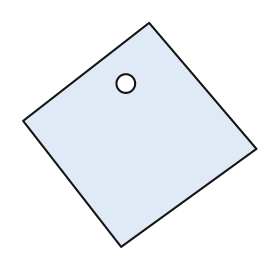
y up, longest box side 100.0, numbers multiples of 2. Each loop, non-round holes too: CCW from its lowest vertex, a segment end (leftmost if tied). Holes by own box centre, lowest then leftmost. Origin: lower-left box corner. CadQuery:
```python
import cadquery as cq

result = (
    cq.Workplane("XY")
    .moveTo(42.0, 0.0)
    .lineTo(100.0, 42.0)
    .lineTo(54.0, 96.0)
    .lineTo(0.0, 54.0)
    .close()
    .moveTo(44.0, 70.0)
    .circle(4.0)
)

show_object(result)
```